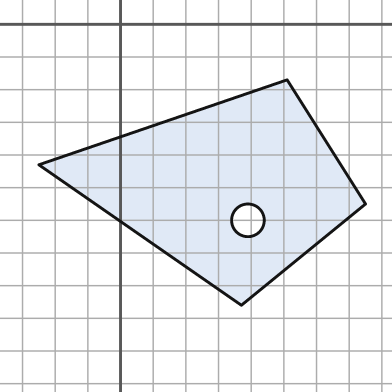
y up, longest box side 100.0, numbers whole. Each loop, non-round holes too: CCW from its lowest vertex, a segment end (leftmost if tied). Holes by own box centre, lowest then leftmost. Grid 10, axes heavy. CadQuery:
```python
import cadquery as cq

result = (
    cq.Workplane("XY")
    .moveTo(37.0, -86.0)
    .lineTo(75.0, -55.0)
    .lineTo(51.0, -17.0)
    .lineTo(-25.0, -43.0)
    .close()
    .moveTo(39.0, -60.0)
    .circle(5.0)
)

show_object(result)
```